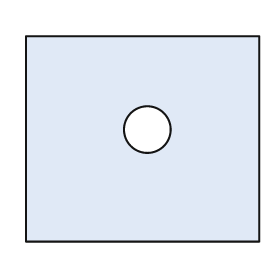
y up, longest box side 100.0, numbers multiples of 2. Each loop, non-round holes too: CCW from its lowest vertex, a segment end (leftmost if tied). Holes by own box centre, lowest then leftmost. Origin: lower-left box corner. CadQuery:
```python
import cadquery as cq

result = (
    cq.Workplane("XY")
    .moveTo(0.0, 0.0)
    .lineTo(100.0, 0.0)
    .lineTo(100.0, 88.0)
    .lineTo(0.0, 88.0)
    .close()
    .moveTo(52.0, 48.0)
    .circle(10.0)
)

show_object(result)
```